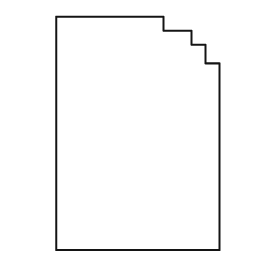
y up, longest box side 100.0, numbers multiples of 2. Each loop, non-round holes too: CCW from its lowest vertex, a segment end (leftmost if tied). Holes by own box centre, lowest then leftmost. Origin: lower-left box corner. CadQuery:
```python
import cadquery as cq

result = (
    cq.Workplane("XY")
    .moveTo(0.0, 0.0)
    .lineTo(70.0, 0.0)
    .lineTo(70.0, 80.0)
    .lineTo(64.0, 80.0)
    .lineTo(64.0, 88.0)
    .lineTo(58.0, 88.0)
    .lineTo(58.0, 94.0)
    .lineTo(46.0, 94.0)
    .lineTo(46.0, 100.0)
    .lineTo(0.0, 100.0)
    .close()
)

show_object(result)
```